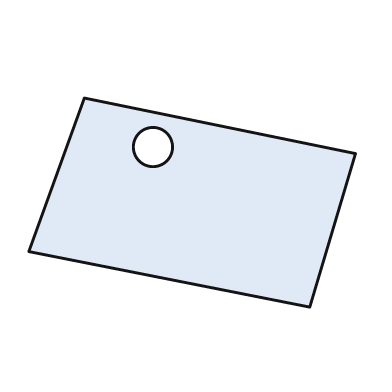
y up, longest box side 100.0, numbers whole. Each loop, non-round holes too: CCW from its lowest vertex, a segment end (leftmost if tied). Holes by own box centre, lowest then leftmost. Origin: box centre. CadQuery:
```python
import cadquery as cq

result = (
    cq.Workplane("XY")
    .moveTo(36.0, -32.0)
    .lineTo(50.0, 15.0)
    .lineTo(-33.0, 32.0)
    .lineTo(-50.0, -15.0)
    .close()
    .moveTo(-12.0, 17.0)
    .circle(6.0)
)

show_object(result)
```